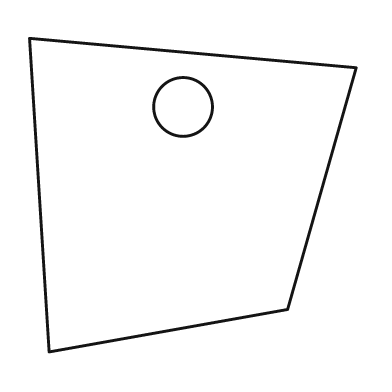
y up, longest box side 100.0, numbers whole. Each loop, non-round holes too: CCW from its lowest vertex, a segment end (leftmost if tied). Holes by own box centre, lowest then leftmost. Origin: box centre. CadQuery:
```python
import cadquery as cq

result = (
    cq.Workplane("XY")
    .moveTo(-44.0, -48.0)
    .lineTo(29.0, -35.0)
    .lineTo(50.0, 39.0)
    .lineTo(-50.0, 48.0)
    .close()
    .moveTo(-3.0, 27.0)
    .circle(9.0)
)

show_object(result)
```